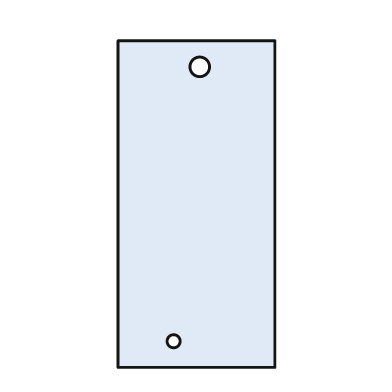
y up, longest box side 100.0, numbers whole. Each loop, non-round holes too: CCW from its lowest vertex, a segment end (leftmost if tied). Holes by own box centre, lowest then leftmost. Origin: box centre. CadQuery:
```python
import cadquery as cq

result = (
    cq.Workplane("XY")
    .moveTo(-24.0, -50.0)
    .lineTo(24.0, -50.0)
    .lineTo(24.0, 50.0)
    .lineTo(-24.0, 50.0)
    .close()
    .moveTo(-7.0, -42.0)
    .circle(2.0)
    .moveTo(1.0, 42.0)
    .circle(3.0)
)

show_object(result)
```